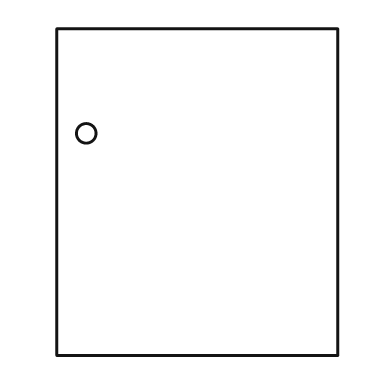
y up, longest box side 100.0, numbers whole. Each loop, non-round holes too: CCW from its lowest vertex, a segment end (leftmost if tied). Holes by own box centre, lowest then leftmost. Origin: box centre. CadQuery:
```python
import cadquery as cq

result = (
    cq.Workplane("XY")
    .moveTo(-43.0, -50.0)
    .lineTo(43.0, -50.0)
    .lineTo(43.0, 50.0)
    .lineTo(-43.0, 50.0)
    .close()
    .moveTo(-34.0, 18.0)
    .circle(3.0)
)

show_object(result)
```